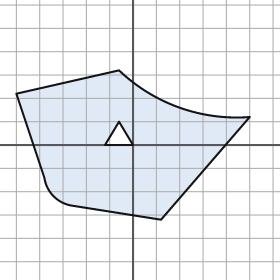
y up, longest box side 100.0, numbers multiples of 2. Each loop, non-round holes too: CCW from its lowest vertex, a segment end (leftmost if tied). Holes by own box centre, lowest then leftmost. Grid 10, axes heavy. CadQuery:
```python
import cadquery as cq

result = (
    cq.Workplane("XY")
    .moveTo(12.0, -32.0)
    .lineTo(50.0, 12.0)
    .threePointArc((20.0, 16.0), (-6.0, 32.0))
    .lineTo(-50.0, 22.0)
    .lineTo(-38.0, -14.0)
    .threePointArc((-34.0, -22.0), (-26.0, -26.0))
    .close()
    .moveTo(-12.0, 0.0)
    .lineTo(0.0, 0.0)
    .lineTo(-6.0, 10.0)
    .close()
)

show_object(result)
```